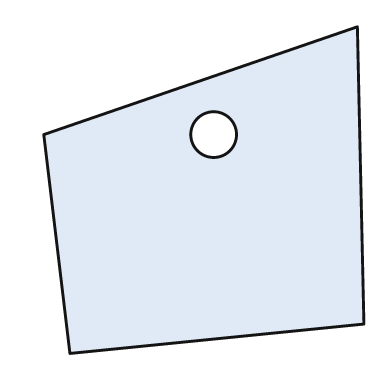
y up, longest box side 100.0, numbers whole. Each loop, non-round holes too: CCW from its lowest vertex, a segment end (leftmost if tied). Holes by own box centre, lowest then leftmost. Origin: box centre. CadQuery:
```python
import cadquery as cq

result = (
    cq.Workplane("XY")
    .moveTo(-41.0, -50.0)
    .lineTo(49.0, -41.0)
    .lineTo(47.0, 50.0)
    .lineTo(-49.0, 17.0)
    .close()
    .moveTo(3.0, 17.0)
    .circle(7.0)
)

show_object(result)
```